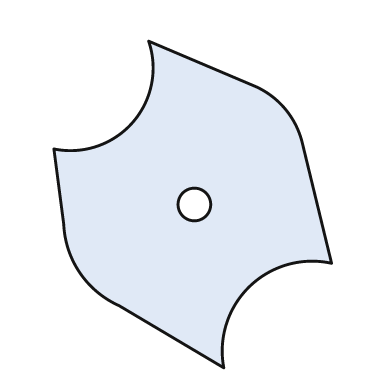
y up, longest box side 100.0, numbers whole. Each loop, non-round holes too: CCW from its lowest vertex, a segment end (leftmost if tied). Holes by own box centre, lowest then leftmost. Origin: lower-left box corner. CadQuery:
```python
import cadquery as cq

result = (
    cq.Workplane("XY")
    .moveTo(52.0, 0.0)
    .threePointArc((60.0, 25.0), (85.0, 32.0))
    .lineTo(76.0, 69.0)
    .threePointArc((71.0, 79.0), (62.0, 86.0))
    .lineTo(29.0, 100.0)
    .threePointArc((24.0, 75.0), (0.0, 67.0))
    .lineTo(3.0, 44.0)
    .threePointArc((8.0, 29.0), (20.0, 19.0))
    .close()
    .moveTo(43.0, 50.0)
    .circle(5.0)
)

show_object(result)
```